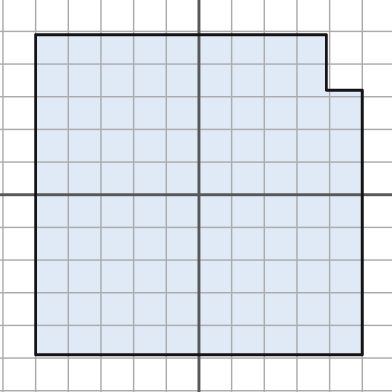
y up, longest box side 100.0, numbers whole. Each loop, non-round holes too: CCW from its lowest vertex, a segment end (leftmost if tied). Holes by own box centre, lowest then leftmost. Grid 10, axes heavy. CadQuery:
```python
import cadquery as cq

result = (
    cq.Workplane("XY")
    .moveTo(-50.0, -49.0)
    .lineTo(50.0, -49.0)
    .lineTo(50.0, 32.0)
    .lineTo(39.0, 32.0)
    .lineTo(39.0, 49.0)
    .lineTo(-50.0, 49.0)
    .close()
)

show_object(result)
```